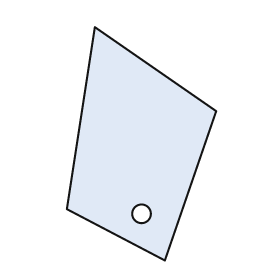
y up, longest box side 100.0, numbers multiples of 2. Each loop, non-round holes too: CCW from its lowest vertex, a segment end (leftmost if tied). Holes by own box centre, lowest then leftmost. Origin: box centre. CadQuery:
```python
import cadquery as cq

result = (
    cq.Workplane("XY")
    .moveTo(10.0, -50.0)
    .lineTo(32.0, 14.0)
    .lineTo(-20.0, 50.0)
    .lineTo(-32.0, -28.0)
    .close()
    .moveTo(0.0, -30.0)
    .circle(4.0)
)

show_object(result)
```